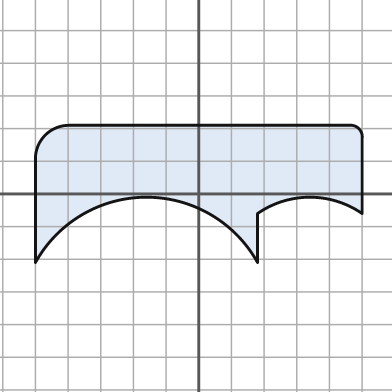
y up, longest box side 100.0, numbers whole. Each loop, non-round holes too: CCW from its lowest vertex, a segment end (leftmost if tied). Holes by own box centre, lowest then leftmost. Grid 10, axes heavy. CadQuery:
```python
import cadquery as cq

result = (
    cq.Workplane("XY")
    .moveTo(-50.0, -21.0)
    .threePointArc((-16.0, -1.0), (18.0, -21.0))
    .lineTo(18.0, -6.0)
    .threePointArc((34.0, -1.0), (50.0, -6.0))
    .lineTo(50.0, 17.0)
    .threePointArc((49.0, 20.0), (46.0, 21.0))
    .lineTo(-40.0, 21.0)
    .threePointArc((-47.0, 18.0), (-50.0, 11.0))
    .close()
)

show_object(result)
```